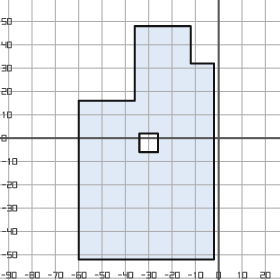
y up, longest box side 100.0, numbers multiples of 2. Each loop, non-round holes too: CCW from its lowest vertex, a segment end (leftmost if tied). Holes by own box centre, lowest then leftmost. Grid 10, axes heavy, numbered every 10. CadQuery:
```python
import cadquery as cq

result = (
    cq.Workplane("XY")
    .moveTo(-60.0, -52.0)
    .lineTo(-2.0, -52.0)
    .lineTo(-2.0, 32.0)
    .lineTo(-12.0, 32.0)
    .lineTo(-12.0, 48.0)
    .lineTo(-36.0, 48.0)
    .lineTo(-36.0, 16.0)
    .lineTo(-60.0, 16.0)
    .close()
    .moveTo(-34.0, -6.0)
    .lineTo(-26.0, -6.0)
    .lineTo(-26.0, 2.0)
    .lineTo(-34.0, 2.0)
    .close()
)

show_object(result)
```